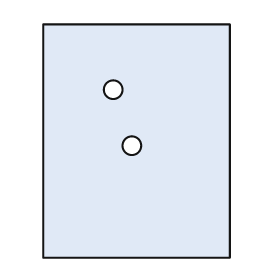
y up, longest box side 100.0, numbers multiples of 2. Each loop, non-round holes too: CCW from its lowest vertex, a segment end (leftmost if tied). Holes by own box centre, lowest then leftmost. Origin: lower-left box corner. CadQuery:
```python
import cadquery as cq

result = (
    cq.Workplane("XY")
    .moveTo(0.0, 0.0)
    .lineTo(80.0, 0.0)
    .lineTo(80.0, 100.0)
    .lineTo(0.0, 100.0)
    .close()
    .moveTo(38.0, 48.0)
    .circle(4.0)
    .moveTo(30.0, 72.0)
    .circle(4.0)
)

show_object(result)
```